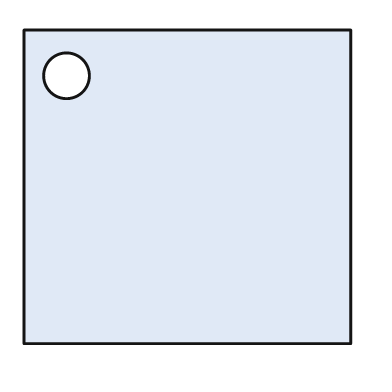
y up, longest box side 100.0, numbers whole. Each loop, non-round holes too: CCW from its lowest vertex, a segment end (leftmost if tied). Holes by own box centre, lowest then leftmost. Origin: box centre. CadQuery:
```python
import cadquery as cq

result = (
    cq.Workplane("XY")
    .moveTo(-50.0, -48.0)
    .lineTo(50.0, -48.0)
    .lineTo(50.0, 48.0)
    .lineTo(-50.0, 48.0)
    .close()
    .moveTo(-37.0, 34.0)
    .circle(7.0)
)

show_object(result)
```